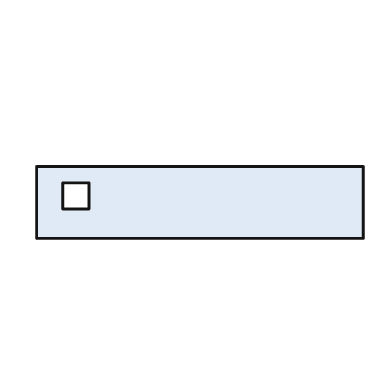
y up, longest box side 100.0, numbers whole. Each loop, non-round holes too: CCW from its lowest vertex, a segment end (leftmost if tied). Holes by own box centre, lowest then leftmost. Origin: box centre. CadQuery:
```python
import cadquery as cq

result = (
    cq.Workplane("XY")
    .moveTo(-50.0, -11.0)
    .lineTo(50.0, -11.0)
    .lineTo(50.0, 11.0)
    .lineTo(-50.0, 11.0)
    .close()
    .moveTo(-42.0, -2.0)
    .lineTo(-34.0, -2.0)
    .lineTo(-34.0, 6.0)
    .lineTo(-42.0, 6.0)
    .close()
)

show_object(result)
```